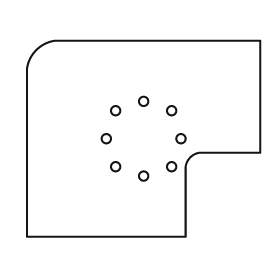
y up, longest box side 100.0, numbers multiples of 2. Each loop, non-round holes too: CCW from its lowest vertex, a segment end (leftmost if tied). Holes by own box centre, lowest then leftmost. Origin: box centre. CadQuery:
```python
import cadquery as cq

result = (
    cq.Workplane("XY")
    .moveTo(-50.0, -42.0)
    .lineTo(18.0, -42.0)
    .lineTo(18.0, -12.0)
    .threePointArc((20.0, -8.0), (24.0, -6.0))
    .lineTo(50.0, -6.0)
    .lineTo(50.0, 42.0)
    .lineTo(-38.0, 42.0)
    .threePointArc((-46.0, 38.0), (-50.0, 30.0))
    .close()
    .moveTo(0.0, -16.0)
    .circle(2.0)
    .moveTo(-12.0, -12.0)
    .circle(2.0)
    .moveTo(12.0, -12.0)
    .circle(2.0)
    .moveTo(-16.0, 0.0)
    .circle(2.0)
    .moveTo(16.0, 0.0)
    .circle(2.0)
    .moveTo(-12.0, 12.0)
    .circle(2.0)
    .moveTo(12.0, 12.0)
    .circle(2.0)
    .moveTo(0.0, 16.0)
    .circle(2.0)
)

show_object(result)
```